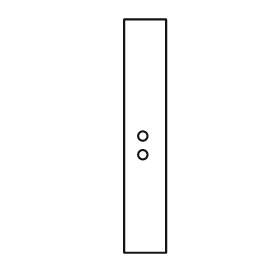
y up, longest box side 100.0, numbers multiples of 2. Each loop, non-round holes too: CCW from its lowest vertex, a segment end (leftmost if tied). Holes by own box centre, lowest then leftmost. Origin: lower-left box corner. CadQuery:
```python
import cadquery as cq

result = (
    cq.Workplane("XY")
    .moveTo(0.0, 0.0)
    .lineTo(18.0, 0.0)
    .lineTo(18.0, 100.0)
    .lineTo(0.0, 100.0)
    .close()
    .moveTo(8.0, 42.0)
    .circle(2.0)
    .moveTo(8.0, 50.0)
    .circle(2.0)
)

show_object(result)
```